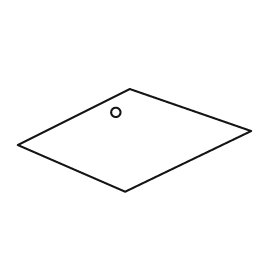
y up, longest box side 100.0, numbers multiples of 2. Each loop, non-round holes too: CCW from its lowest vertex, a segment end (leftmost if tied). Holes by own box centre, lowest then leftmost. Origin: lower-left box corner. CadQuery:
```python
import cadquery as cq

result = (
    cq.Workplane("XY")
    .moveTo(46.0, 0.0)
    .lineTo(100.0, 26.0)
    .lineTo(48.0, 44.0)
    .lineTo(0.0, 20.0)
    .close()
    .moveTo(42.0, 34.0)
    .circle(2.0)
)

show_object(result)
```